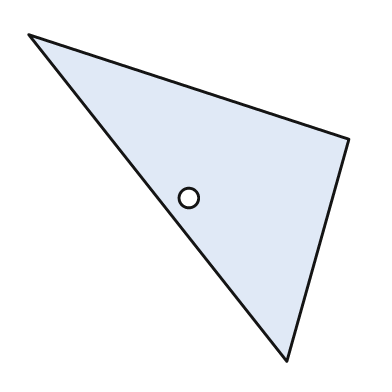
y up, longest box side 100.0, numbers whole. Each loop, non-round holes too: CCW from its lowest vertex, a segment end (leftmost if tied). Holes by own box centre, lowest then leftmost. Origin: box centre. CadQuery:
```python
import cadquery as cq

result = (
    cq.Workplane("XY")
    .moveTo(30.0, -50.0)
    .lineTo(49.0, 18.0)
    .lineTo(-49.0, 50.0)
    .close()
    .moveTo(0.0, 0.0)
    .circle(3.0)
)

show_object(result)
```